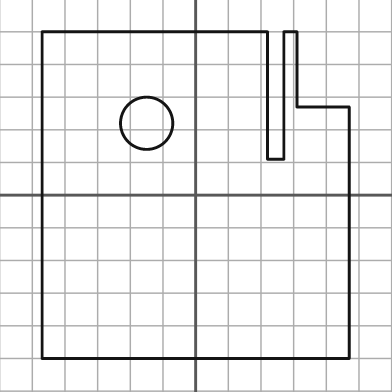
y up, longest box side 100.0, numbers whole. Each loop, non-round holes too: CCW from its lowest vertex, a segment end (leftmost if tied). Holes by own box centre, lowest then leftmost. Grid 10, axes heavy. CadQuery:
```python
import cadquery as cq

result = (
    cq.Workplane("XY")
    .moveTo(-47.0, -50.0)
    .lineTo(47.0, -50.0)
    .lineTo(47.0, 27.0)
    .lineTo(31.0, 27.0)
    .lineTo(31.0, 50.0)
    .lineTo(27.0, 50.0)
    .lineTo(27.0, 11.0)
    .lineTo(22.0, 11.0)
    .lineTo(22.0, 50.0)
    .lineTo(-47.0, 50.0)
    .close()
    .moveTo(-15.0, 22.0)
    .circle(8.0)
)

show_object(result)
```